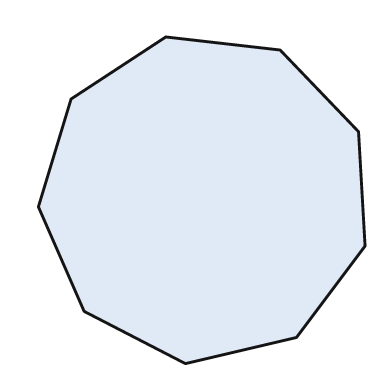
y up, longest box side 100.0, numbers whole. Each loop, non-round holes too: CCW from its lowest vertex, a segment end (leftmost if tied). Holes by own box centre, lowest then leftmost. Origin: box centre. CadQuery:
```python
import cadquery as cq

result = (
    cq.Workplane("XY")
    .moveTo(-5.0, -50.0)
    .lineTo(29.0, -42.0)
    .lineTo(50.0, -14.0)
    .lineTo(48.0, 21.0)
    .lineTo(24.0, 46.0)
    .lineTo(-11.0, 50.0)
    .lineTo(-40.0, 31.0)
    .lineTo(-50.0, -2.0)
    .lineTo(-36.0, -34.0)
    .close()
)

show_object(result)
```